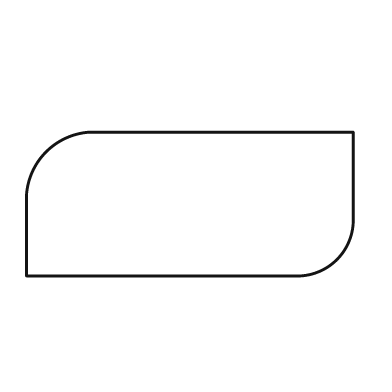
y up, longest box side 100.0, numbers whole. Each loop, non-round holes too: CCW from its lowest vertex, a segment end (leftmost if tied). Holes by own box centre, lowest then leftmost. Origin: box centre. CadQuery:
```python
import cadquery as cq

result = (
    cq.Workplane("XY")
    .moveTo(-50.0, -22.0)
    .lineTo(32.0, -22.0)
    .threePointArc((45.0, -17.0), (50.0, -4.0))
    .lineTo(50.0, 22.0)
    .lineTo(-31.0, 22.0)
    .threePointArc((-44.0, 16.0), (-50.0, 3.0))
    .close()
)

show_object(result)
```